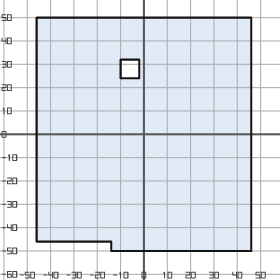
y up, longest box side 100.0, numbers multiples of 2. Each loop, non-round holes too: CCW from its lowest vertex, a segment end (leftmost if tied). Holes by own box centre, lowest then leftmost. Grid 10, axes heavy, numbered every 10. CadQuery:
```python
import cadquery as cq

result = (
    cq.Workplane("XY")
    .moveTo(-14.0, -50.0)
    .lineTo(46.0, -50.0)
    .lineTo(46.0, 50.0)
    .lineTo(-46.0, 50.0)
    .lineTo(-46.0, -46.0)
    .lineTo(-14.0, -46.0)
    .close()
    .moveTo(-10.0, 24.0)
    .lineTo(-2.0, 24.0)
    .lineTo(-2.0, 32.0)
    .lineTo(-10.0, 32.0)
    .close()
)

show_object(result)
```